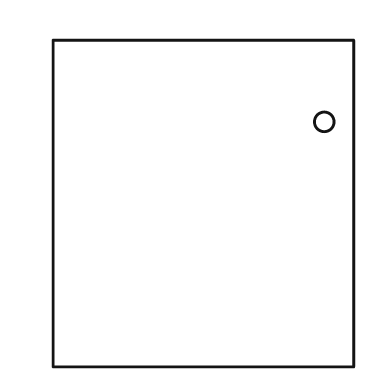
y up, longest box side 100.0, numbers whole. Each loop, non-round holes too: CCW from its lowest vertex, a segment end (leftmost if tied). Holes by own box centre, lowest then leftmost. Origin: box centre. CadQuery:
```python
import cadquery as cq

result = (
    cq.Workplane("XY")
    .moveTo(-46.0, -50.0)
    .lineTo(46.0, -50.0)
    .lineTo(46.0, 50.0)
    .lineTo(-46.0, 50.0)
    .close()
    .moveTo(37.0, 25.0)
    .circle(3.0)
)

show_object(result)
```